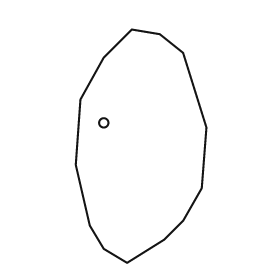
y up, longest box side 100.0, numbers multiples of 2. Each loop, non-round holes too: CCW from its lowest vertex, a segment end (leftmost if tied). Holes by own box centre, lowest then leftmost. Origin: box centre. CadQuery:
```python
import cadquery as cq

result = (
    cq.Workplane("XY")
    .moveTo(-6.0, -50.0)
    .lineTo(10.0, -40.0)
    .lineTo(18.0, -32.0)
    .lineTo(26.0, -18.0)
    .lineTo(28.0, 8.0)
    .lineTo(18.0, 40.0)
    .lineTo(8.0, 48.0)
    .lineTo(-4.0, 50.0)
    .lineTo(-16.0, 38.0)
    .lineTo(-26.0, 20.0)
    .lineTo(-28.0, -8.0)
    .lineTo(-22.0, -34.0)
    .lineTo(-16.0, -44.0)
    .close()
    .moveTo(-16.0, 10.0)
    .circle(2.0)
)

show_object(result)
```